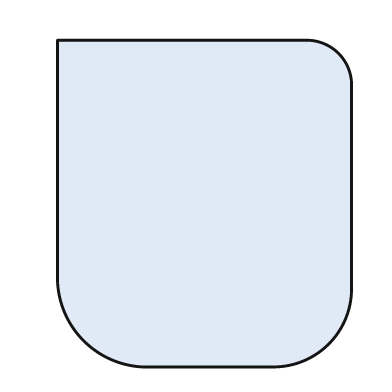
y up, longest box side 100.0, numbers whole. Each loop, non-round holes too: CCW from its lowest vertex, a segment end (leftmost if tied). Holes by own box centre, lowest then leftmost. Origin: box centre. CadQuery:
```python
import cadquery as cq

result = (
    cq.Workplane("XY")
    .moveTo(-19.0, -50.0)
    .lineTo(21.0, -50.0)
    .threePointArc((38.0, -43.0), (45.0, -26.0))
    .lineTo(45.0, 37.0)
    .threePointArc((41.0, 46.0), (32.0, 50.0))
    .lineTo(-45.0, 50.0)
    .lineTo(-45.0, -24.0)
    .threePointArc((-37.0, -42.0), (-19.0, -50.0))
    .close()
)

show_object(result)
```